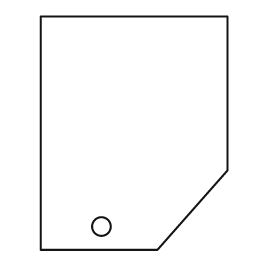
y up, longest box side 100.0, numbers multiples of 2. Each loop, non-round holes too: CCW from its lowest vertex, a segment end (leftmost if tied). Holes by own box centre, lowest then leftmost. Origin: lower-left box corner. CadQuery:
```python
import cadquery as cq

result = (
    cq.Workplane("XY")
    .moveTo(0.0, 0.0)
    .lineTo(50.0, 0.0)
    .lineTo(80.0, 34.0)
    .lineTo(80.0, 100.0)
    .lineTo(0.0, 100.0)
    .close()
    .moveTo(26.0, 10.0)
    .circle(4.0)
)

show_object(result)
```